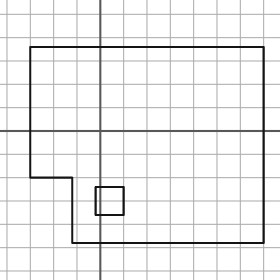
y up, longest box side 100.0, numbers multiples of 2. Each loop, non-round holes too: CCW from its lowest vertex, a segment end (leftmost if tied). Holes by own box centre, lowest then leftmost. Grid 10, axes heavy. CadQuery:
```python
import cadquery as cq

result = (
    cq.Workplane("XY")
    .moveTo(-12.0, -48.0)
    .lineTo(70.0, -48.0)
    .lineTo(70.0, 36.0)
    .lineTo(-30.0, 36.0)
    .lineTo(-30.0, -20.0)
    .lineTo(-12.0, -20.0)
    .close()
    .moveTo(-2.0, -36.0)
    .lineTo(10.0, -36.0)
    .lineTo(10.0, -24.0)
    .lineTo(-2.0, -24.0)
    .close()
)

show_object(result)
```